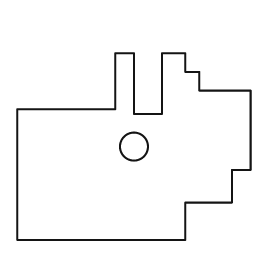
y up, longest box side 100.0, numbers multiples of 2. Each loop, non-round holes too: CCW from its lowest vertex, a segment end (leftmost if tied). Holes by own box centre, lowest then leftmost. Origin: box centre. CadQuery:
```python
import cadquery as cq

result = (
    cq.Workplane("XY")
    .moveTo(-50.0, -40.0)
    .lineTo(22.0, -40.0)
    .lineTo(22.0, -24.0)
    .lineTo(42.0, -24.0)
    .lineTo(42.0, -10.0)
    .lineTo(50.0, -10.0)
    .lineTo(50.0, 24.0)
    .lineTo(28.0, 24.0)
    .lineTo(28.0, 32.0)
    .lineTo(22.0, 32.0)
    .lineTo(22.0, 40.0)
    .lineTo(12.0, 40.0)
    .lineTo(12.0, 14.0)
    .lineTo(0.0, 14.0)
    .lineTo(0.0, 40.0)
    .lineTo(-8.0, 40.0)
    .lineTo(-8.0, 16.0)
    .lineTo(-50.0, 16.0)
    .close()
    .moveTo(0.0, 0.0)
    .circle(6.0)
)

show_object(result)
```